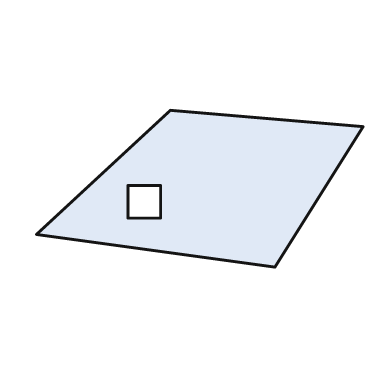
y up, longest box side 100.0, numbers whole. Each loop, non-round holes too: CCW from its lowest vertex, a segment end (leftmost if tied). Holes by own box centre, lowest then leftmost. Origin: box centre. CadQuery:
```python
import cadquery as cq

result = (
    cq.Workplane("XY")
    .moveTo(23.0, -24.0)
    .lineTo(50.0, 19.0)
    .lineTo(-9.0, 24.0)
    .lineTo(-50.0, -14.0)
    .close()
    .moveTo(-22.0, -9.0)
    .lineTo(-12.0, -9.0)
    .lineTo(-12.0, 1.0)
    .lineTo(-22.0, 1.0)
    .close()
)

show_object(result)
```